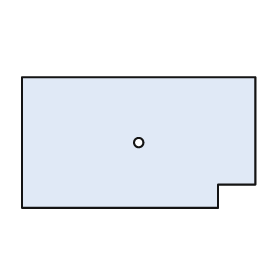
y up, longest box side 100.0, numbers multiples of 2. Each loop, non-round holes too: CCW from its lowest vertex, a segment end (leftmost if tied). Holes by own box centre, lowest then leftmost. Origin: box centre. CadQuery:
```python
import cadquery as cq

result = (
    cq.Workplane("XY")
    .moveTo(-50.0, -28.0)
    .lineTo(34.0, -28.0)
    .lineTo(34.0, -18.0)
    .lineTo(50.0, -18.0)
    .lineTo(50.0, 28.0)
    .lineTo(-50.0, 28.0)
    .close()
    .moveTo(0.0, 0.0)
    .circle(2.0)
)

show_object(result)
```